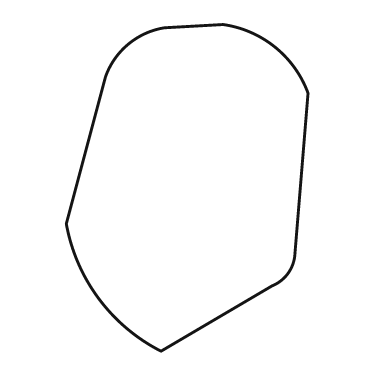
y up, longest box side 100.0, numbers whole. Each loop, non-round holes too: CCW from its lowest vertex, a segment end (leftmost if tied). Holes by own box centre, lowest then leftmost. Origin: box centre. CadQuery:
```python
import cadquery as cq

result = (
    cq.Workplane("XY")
    .moveTo(-8.0, -50.0)
    .lineTo(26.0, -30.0)
    .threePointArc((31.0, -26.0), (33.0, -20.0))
    .lineTo(37.0, 29.0)
    .threePointArc((27.0, 43.0), (11.0, 50.0))
    .lineTo(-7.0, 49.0)
    .threePointArc((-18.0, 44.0), (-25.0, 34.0))
    .lineTo(-37.0, -11.0)
    .threePointArc((-27.0, -34.0), (-8.0, -50.0))
    .close()
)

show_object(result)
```